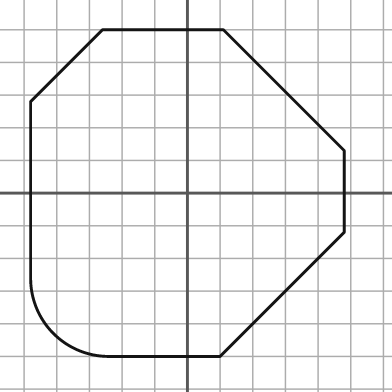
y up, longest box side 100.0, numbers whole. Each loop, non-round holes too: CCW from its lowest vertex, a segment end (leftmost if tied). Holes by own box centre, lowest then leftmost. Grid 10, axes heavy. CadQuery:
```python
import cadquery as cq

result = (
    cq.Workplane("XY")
    .moveTo(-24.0, -50.0)
    .lineTo(10.0, -50.0)
    .lineTo(48.0, -12.0)
    .lineTo(48.0, 13.0)
    .lineTo(11.0, 50.0)
    .lineTo(-26.0, 50.0)
    .lineTo(-48.0, 28.0)
    .lineTo(-48.0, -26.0)
    .threePointArc((-41.0, -43.0), (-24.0, -50.0))
    .close()
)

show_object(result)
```